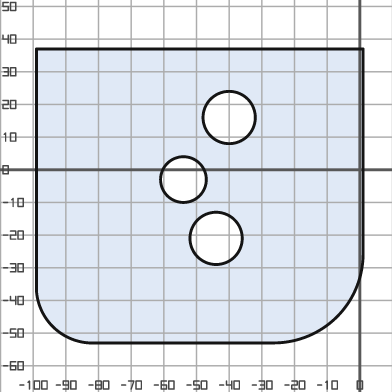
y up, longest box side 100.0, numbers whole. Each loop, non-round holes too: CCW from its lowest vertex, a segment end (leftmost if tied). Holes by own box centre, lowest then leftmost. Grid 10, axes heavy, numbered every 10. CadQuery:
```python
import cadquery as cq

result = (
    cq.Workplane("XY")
    .moveTo(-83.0, -53.0)
    .lineTo(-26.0, -53.0)
    .threePointArc((-7.0, -45.0), (1.0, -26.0))
    .lineTo(1.0, 37.0)
    .lineTo(-99.0, 37.0)
    .lineTo(-99.0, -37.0)
    .threePointArc((-94.0, -48.0), (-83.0, -53.0))
    .close()
    .moveTo(-44.0, -21.0)
    .circle(8.0)
    .moveTo(-54.0, -3.0)
    .circle(7.0)
    .moveTo(-40.0, 16.0)
    .circle(8.0)
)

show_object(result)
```